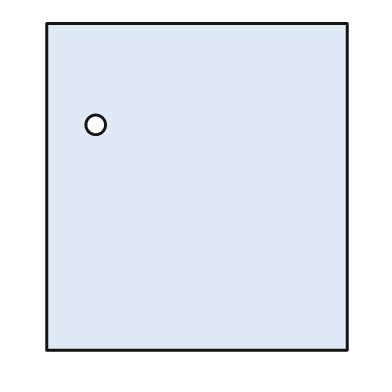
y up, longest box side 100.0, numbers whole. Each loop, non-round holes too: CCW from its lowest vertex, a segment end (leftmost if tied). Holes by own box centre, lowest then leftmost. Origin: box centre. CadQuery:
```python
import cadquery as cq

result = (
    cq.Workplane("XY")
    .moveTo(-46.0, -50.0)
    .lineTo(46.0, -50.0)
    .lineTo(46.0, 50.0)
    .lineTo(-46.0, 50.0)
    .close()
    .moveTo(-31.0, 19.0)
    .circle(3.0)
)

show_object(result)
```